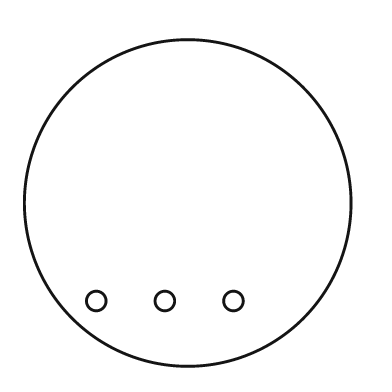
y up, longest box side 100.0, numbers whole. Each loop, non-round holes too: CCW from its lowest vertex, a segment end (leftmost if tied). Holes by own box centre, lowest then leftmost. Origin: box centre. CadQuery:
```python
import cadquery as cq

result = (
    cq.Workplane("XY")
    .moveTo(0.0, 0.0)
    .circle(50.0)
    .moveTo(-28.0, -30.0)
    .circle(3.0)
    .moveTo(-7.0, -30.0)
    .circle(3.0)
    .moveTo(14.0, -30.0)
    .circle(3.0)
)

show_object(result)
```